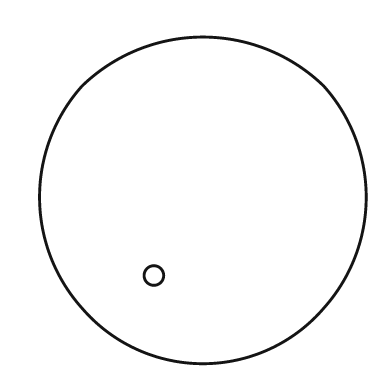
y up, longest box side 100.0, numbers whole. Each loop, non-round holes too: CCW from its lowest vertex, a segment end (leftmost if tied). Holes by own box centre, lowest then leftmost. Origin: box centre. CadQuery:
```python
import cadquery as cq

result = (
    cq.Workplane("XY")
    .moveTo(-37.0, -33.0)
    .threePointArc((0.0, -50.0), (37.0, -33.0))
    .threePointArc((50.0, 1.0), (37.0, 35.0))
    .threePointArc((0.0, 50.0), (-37.0, 35.0))
    .threePointArc((-50.0, 1.0), (-37.0, -33.0))
    .close()
    .moveTo(-15.0, -23.0)
    .circle(3.0)
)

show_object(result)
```